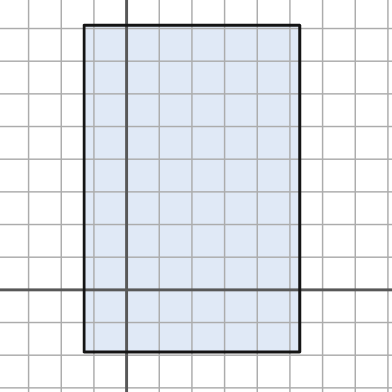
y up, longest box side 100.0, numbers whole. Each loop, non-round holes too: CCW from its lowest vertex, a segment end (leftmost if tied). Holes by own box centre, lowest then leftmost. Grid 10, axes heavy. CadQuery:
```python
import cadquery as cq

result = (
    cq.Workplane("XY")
    .moveTo(-13.0, -19.0)
    .lineTo(53.0, -19.0)
    .lineTo(53.0, 81.0)
    .lineTo(-13.0, 81.0)
    .close()
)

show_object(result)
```